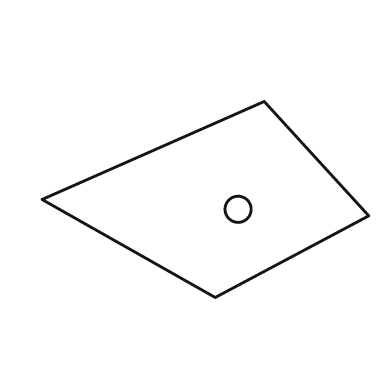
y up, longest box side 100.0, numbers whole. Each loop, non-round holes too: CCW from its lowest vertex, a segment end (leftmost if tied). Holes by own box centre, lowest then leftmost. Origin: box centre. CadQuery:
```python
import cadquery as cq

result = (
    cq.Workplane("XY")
    .moveTo(3.0, -30.0)
    .lineTo(50.0, -5.0)
    .lineTo(18.0, 30.0)
    .lineTo(-50.0, 0.0)
    .close()
    .moveTo(10.0, -3.0)
    .circle(4.0)
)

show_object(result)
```